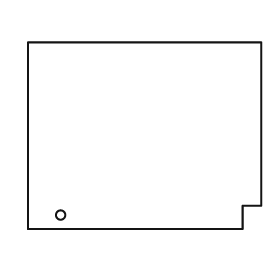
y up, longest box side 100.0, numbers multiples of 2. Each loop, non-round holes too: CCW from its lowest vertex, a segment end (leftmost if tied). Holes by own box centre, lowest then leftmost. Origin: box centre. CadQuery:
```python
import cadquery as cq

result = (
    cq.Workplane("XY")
    .moveTo(-50.0, -40.0)
    .lineTo(42.0, -40.0)
    .lineTo(42.0, -30.0)
    .lineTo(50.0, -30.0)
    .lineTo(50.0, 40.0)
    .lineTo(-50.0, 40.0)
    .close()
    .moveTo(-36.0, -34.0)
    .circle(2.0)
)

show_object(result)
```